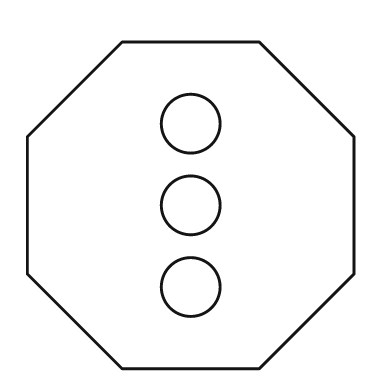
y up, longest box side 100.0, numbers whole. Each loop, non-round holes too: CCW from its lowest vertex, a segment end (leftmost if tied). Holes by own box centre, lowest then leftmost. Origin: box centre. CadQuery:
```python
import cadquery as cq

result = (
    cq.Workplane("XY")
    .moveTo(-21.0, -50.0)
    .lineTo(21.0, -50.0)
    .lineTo(50.0, -21.0)
    .lineTo(50.0, 21.0)
    .lineTo(21.0, 50.0)
    .lineTo(-21.0, 50.0)
    .lineTo(-50.0, 21.0)
    .lineTo(-50.0, -21.0)
    .close()
    .moveTo(0.0, -25.0)
    .circle(9.0)
    .moveTo(0.0, 0.0)
    .circle(9.0)
    .moveTo(0.0, 25.0)
    .circle(9.0)
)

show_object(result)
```